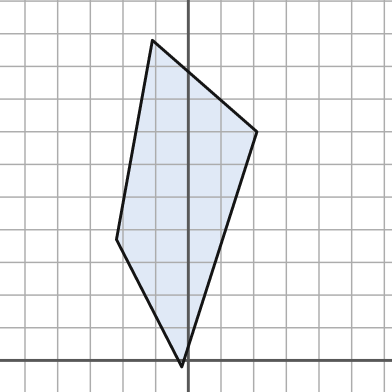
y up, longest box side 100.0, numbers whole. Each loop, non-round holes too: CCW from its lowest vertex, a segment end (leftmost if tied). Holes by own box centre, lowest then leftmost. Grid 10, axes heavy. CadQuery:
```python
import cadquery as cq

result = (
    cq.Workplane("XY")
    .moveTo(-2.0, -2.0)
    .lineTo(21.0, 70.0)
    .lineTo(-11.0, 98.0)
    .lineTo(-22.0, 37.0)
    .close()
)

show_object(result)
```